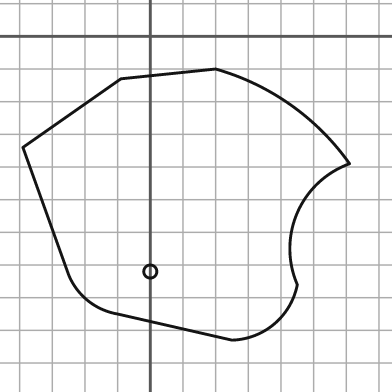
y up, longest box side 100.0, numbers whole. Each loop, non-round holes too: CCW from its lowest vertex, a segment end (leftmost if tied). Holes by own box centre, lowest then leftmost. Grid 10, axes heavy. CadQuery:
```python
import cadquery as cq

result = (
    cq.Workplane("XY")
    .moveTo(25.0, -93.0)
    .threePointArc((38.0, -88.0), (45.0, -76.0))
    .threePointArc((45.0, -54.0), (61.0, -39.0))
    .threePointArc((43.0, -21.0), (20.0, -10.0))
    .lineTo(-9.0, -13.0)
    .lineTo(-39.0, -34.0)
    .lineTo(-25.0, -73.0)
    .threePointArc((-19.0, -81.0), (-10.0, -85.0))
    .close()
    .moveTo(0.0, -72.0)
    .circle(2.0)
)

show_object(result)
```